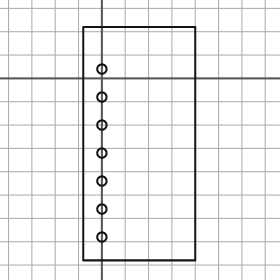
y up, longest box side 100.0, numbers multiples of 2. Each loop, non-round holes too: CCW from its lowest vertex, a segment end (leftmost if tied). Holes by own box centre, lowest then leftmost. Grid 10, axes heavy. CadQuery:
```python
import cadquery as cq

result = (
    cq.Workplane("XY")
    .moveTo(-8.0, -78.0)
    .lineTo(40.0, -78.0)
    .lineTo(40.0, 22.0)
    .lineTo(-8.0, 22.0)
    .close()
    .moveTo(0.0, -68.0)
    .circle(2.0)
    .moveTo(0.0, -56.0)
    .circle(2.0)
    .moveTo(0.0, -44.0)
    .circle(2.0)
    .moveTo(0.0, -32.0)
    .circle(2.0)
    .moveTo(0.0, -20.0)
    .circle(2.0)
    .moveTo(0.0, -8.0)
    .circle(2.0)
    .moveTo(0.0, 4.0)
    .circle(2.0)
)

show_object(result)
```